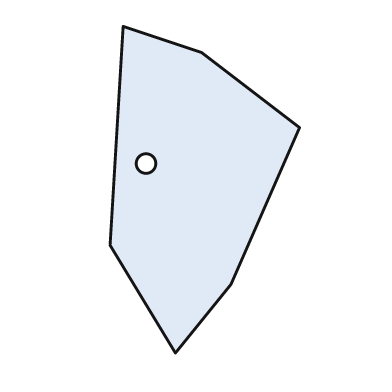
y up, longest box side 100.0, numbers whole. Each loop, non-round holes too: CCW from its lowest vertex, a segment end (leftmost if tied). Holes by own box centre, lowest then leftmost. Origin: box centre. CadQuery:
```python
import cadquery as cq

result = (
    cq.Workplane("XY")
    .moveTo(-9.0, -50.0)
    .lineTo(8.0, -29.0)
    .lineTo(29.0, 19.0)
    .lineTo(-1.0, 42.0)
    .lineTo(-25.0, 50.0)
    .lineTo(-29.0, -17.0)
    .close()
    .moveTo(-18.0, 8.0)
    .circle(3.0)
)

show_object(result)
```